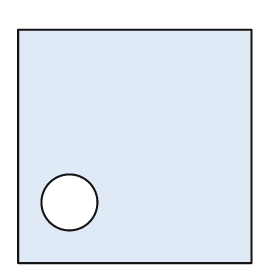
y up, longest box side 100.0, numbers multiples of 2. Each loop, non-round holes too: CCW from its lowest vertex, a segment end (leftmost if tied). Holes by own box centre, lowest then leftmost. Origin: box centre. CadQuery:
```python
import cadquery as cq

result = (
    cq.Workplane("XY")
    .moveTo(-50.0, -50.0)
    .lineTo(50.0, -50.0)
    .lineTo(50.0, 50.0)
    .lineTo(-50.0, 50.0)
    .close()
    .moveTo(-28.0, -24.0)
    .circle(12.0)
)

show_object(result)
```